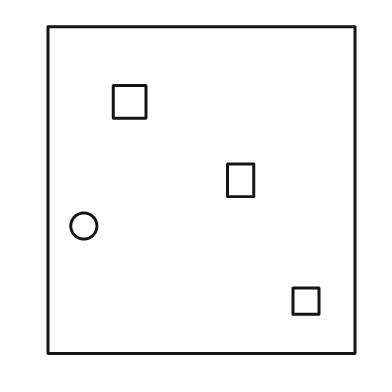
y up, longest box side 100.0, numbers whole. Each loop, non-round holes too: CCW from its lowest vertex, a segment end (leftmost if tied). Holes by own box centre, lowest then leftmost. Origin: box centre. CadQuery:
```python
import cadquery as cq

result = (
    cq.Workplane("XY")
    .moveTo(-47.0, -50.0)
    .lineTo(47.0, -50.0)
    .lineTo(47.0, 50.0)
    .lineTo(-47.0, 50.0)
    .close()
    .moveTo(28.0, -38.0)
    .lineTo(36.0, -38.0)
    .lineTo(36.0, -30.0)
    .lineTo(28.0, -30.0)
    .close()
    .moveTo(-36.0, -11.0)
    .circle(4.0)
    .moveTo(8.0, -2.0)
    .lineTo(16.0, -2.0)
    .lineTo(16.0, 8.0)
    .lineTo(8.0, 8.0)
    .close()
    .moveTo(-27.0, 22.0)
    .lineTo(-17.0, 22.0)
    .lineTo(-17.0, 32.0)
    .lineTo(-27.0, 32.0)
    .close()
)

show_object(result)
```